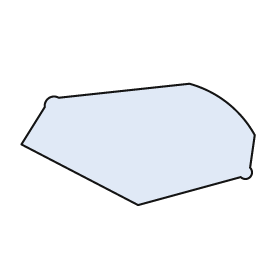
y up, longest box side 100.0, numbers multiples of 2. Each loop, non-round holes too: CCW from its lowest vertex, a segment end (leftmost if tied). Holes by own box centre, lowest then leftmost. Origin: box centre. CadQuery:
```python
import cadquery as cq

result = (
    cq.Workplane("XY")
    .moveTo(0.0, -26.0)
    .lineTo(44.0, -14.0)
    .threePointArc((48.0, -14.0), (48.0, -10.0))
    .lineTo(50.0, 4.0)
    .threePointArc((38.0, 18.0), (22.0, 26.0))
    .lineTo(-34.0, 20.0)
    .threePointArc((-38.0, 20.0), (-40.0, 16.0))
    .lineTo(-50.0, 0.0)
    .close()
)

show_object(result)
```